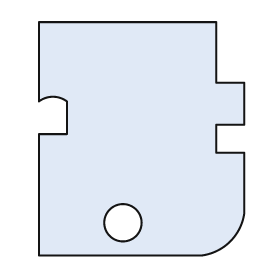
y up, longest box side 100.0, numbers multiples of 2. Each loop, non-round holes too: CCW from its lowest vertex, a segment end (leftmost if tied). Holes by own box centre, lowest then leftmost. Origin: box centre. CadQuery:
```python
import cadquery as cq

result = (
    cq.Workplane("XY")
    .moveTo(-44.0, -50.0)
    .lineTo(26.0, -50.0)
    .threePointArc((38.0, -44.0), (44.0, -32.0))
    .lineTo(44.0, -6.0)
    .lineTo(32.0, -6.0)
    .lineTo(32.0, 6.0)
    .lineTo(44.0, 6.0)
    .lineTo(44.0, 24.0)
    .lineTo(32.0, 24.0)
    .lineTo(32.0, 50.0)
    .lineTo(-44.0, 50.0)
    .lineTo(-44.0, 16.0)
    .threePointArc((-38.0, 18.0), (-32.0, 16.0))
    .lineTo(-32.0, 2.0)
    .lineTo(-44.0, 2.0)
    .close()
    .moveTo(-8.0, -36.0)
    .circle(8.0)
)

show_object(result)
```